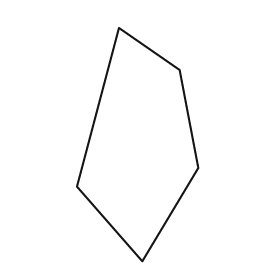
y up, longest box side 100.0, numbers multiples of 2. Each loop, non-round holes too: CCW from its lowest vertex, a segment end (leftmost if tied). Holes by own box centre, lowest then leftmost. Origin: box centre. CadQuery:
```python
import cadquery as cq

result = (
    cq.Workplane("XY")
    .moveTo(2.0, -50.0)
    .lineTo(26.0, -10.0)
    .lineTo(18.0, 32.0)
    .lineTo(-8.0, 50.0)
    .lineTo(-26.0, -18.0)
    .close()
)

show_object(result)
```